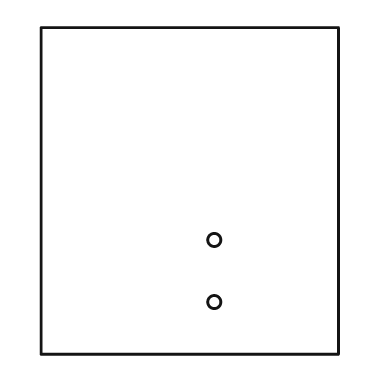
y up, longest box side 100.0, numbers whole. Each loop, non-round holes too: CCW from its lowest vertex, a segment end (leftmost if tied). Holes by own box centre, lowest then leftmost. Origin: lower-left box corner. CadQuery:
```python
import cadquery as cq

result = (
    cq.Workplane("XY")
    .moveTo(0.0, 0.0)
    .lineTo(91.0, 0.0)
    .lineTo(91.0, 100.0)
    .lineTo(0.0, 100.0)
    .close()
    .moveTo(53.0, 16.0)
    .circle(2.0)
    .moveTo(53.0, 35.0)
    .circle(2.0)
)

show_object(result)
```